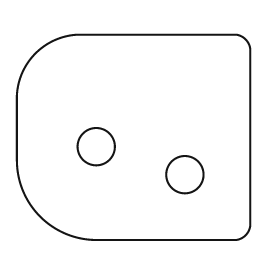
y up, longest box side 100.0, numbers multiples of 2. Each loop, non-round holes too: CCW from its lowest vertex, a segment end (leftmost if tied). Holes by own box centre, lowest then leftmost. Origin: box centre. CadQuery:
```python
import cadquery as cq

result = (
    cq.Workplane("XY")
    .moveTo(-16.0, -44.0)
    .lineTo(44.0, -44.0)
    .threePointArc((48.0, -42.0), (50.0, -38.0))
    .lineTo(50.0, 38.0)
    .threePointArc((48.0, 42.0), (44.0, 44.0))
    .lineTo(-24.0, 44.0)
    .threePointArc((-42.0, 36.0), (-50.0, 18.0))
    .lineTo(-50.0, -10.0)
    .threePointArc((-40.0, -34.0), (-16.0, -44.0))
    .close()
    .moveTo(22.0, -16.0)
    .circle(8.0)
    .moveTo(-16.0, -4.0)
    .circle(8.0)
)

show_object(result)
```